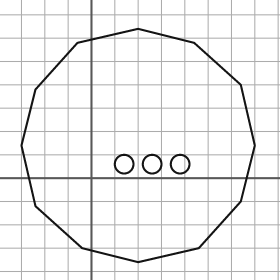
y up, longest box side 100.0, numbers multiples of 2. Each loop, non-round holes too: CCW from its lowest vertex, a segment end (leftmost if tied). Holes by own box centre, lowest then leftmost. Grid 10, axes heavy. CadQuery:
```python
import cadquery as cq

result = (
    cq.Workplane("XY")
    .moveTo(20.0, -36.0)
    .lineTo(46.0, -30.0)
    .lineTo(64.0, -10.0)
    .lineTo(70.0, 14.0)
    .lineTo(64.0, 40.0)
    .lineTo(44.0, 58.0)
    .lineTo(20.0, 64.0)
    .lineTo(-6.0, 58.0)
    .lineTo(-24.0, 38.0)
    .lineTo(-30.0, 14.0)
    .lineTo(-24.0, -12.0)
    .lineTo(-4.0, -30.0)
    .close()
    .moveTo(14.0, 6.0)
    .circle(4.0)
    .moveTo(26.0, 6.0)
    .circle(4.0)
    .moveTo(38.0, 6.0)
    .circle(4.0)
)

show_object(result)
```